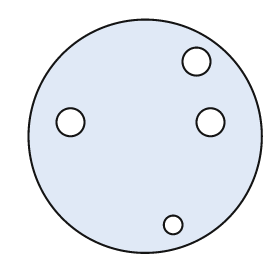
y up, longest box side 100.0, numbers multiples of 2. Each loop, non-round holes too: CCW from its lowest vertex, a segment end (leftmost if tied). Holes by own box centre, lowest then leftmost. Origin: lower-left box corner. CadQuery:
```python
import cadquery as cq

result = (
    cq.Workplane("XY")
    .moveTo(50.0, 50.0)
    .circle(50.0)
    .moveTo(62.0, 12.0)
    .circle(4.0)
    .moveTo(18.0, 56.0)
    .circle(6.0)
    .moveTo(78.0, 56.0)
    .circle(6.0)
    .moveTo(72.0, 82.0)
    .circle(6.0)
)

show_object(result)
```